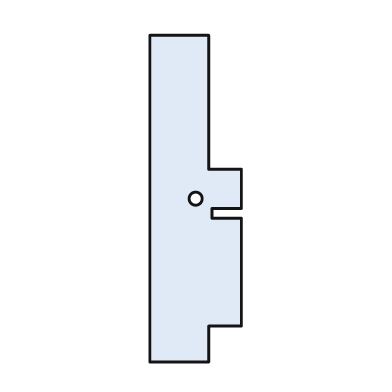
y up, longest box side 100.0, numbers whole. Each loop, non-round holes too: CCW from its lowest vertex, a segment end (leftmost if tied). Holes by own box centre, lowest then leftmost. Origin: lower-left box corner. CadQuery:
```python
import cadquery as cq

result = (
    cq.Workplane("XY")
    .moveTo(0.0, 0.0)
    .lineTo(18.0, 0.0)
    .lineTo(18.0, 11.0)
    .lineTo(28.0, 11.0)
    .lineTo(28.0, 44.0)
    .lineTo(19.0, 44.0)
    .lineTo(19.0, 47.0)
    .lineTo(28.0, 47.0)
    .lineTo(28.0, 59.0)
    .lineTo(18.0, 59.0)
    .lineTo(18.0, 100.0)
    .lineTo(0.0, 100.0)
    .close()
    .moveTo(14.0, 50.0)
    .circle(2.0)
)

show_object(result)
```